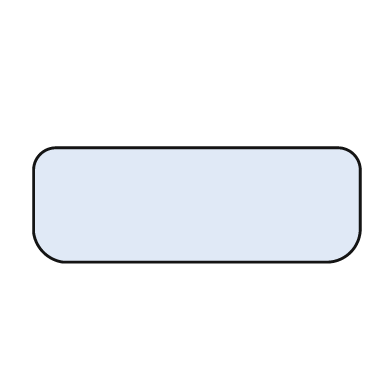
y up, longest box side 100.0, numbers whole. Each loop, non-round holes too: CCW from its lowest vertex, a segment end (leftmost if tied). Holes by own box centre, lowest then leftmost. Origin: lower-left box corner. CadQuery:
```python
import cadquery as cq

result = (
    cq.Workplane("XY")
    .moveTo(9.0, 0.0)
    .lineTo(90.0, 0.0)
    .threePointArc((97.0, 3.0), (100.0, 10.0))
    .lineTo(100.0, 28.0)
    .threePointArc((98.0, 33.0), (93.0, 35.0))
    .lineTo(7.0, 35.0)
    .threePointArc((2.0, 33.0), (0.0, 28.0))
    .lineTo(0.0, 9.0)
    .threePointArc((3.0, 3.0), (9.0, 0.0))
    .close()
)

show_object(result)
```